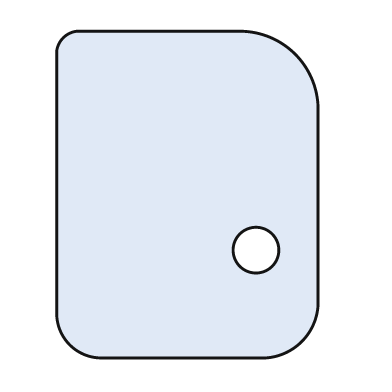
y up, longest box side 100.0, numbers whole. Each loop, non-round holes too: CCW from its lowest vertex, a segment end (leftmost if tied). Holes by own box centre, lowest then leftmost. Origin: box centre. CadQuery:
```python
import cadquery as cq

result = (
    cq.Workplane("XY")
    .moveTo(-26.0, -50.0)
    .lineTo(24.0, -50.0)
    .threePointArc((35.0, -45.0), (40.0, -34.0))
    .lineTo(40.0, 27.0)
    .threePointArc((33.0, 43.0), (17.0, 50.0))
    .lineTo(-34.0, 50.0)
    .threePointArc((-38.0, 48.0), (-40.0, 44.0))
    .lineTo(-40.0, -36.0)
    .threePointArc((-36.0, -46.0), (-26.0, -50.0))
    .close()
    .moveTo(21.0, -17.0)
    .circle(7.0)
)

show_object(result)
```